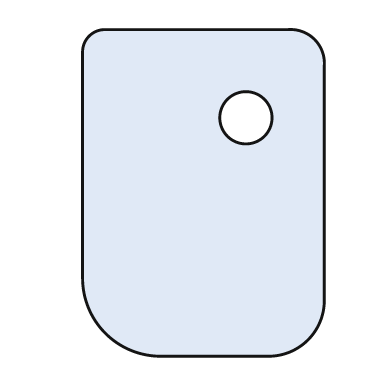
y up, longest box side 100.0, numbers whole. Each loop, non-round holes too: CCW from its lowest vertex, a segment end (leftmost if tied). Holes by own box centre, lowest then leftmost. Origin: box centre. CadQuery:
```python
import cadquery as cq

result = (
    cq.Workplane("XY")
    .moveTo(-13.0, -50.0)
    .lineTo(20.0, -50.0)
    .threePointArc((32.0, -45.0), (37.0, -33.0))
    .lineTo(37.0, 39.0)
    .threePointArc((34.0, 47.0), (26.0, 50.0))
    .lineTo(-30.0, 50.0)
    .threePointArc((-35.0, 48.0), (-37.0, 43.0))
    .lineTo(-37.0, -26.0)
    .threePointArc((-30.0, -43.0), (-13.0, -50.0))
    .close()
    .moveTo(13.0, 23.0)
    .circle(8.0)
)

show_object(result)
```